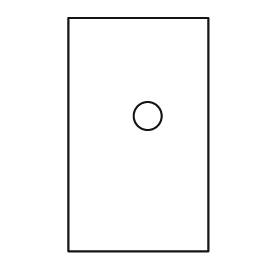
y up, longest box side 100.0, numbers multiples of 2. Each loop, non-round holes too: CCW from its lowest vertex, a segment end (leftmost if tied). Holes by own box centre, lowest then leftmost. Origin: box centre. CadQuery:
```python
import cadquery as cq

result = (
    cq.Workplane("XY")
    .moveTo(-30.0, -50.0)
    .lineTo(30.0, -50.0)
    .lineTo(30.0, 50.0)
    .lineTo(-30.0, 50.0)
    .close()
    .moveTo(4.0, 8.0)
    .circle(6.0)
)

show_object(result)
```